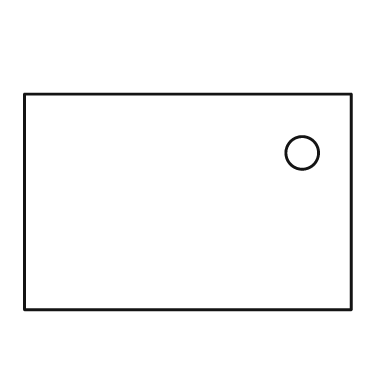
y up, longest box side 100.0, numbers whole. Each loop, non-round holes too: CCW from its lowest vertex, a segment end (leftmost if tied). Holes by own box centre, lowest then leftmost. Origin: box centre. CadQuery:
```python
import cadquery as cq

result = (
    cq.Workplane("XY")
    .moveTo(-50.0, -33.0)
    .lineTo(50.0, -33.0)
    .lineTo(50.0, 33.0)
    .lineTo(-50.0, 33.0)
    .close()
    .moveTo(35.0, 15.0)
    .circle(5.0)
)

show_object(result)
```